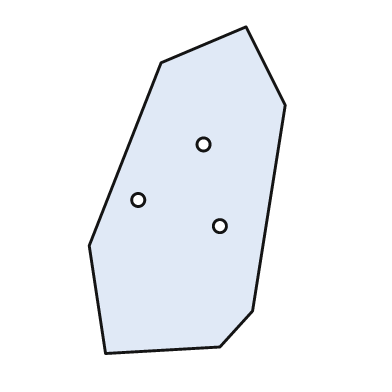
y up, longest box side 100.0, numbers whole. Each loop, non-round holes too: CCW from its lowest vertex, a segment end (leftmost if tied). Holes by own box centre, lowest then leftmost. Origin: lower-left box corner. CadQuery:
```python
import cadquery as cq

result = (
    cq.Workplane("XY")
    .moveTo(5.0, 0.0)
    .lineTo(40.0, 2.0)
    .lineTo(50.0, 13.0)
    .lineTo(60.0, 76.0)
    .lineTo(48.0, 100.0)
    .lineTo(22.0, 89.0)
    .lineTo(0.0, 33.0)
    .close()
    .moveTo(40.0, 39.0)
    .circle(2.0)
    .moveTo(15.0, 47.0)
    .circle(2.0)
    .moveTo(35.0, 64.0)
    .circle(2.0)
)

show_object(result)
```